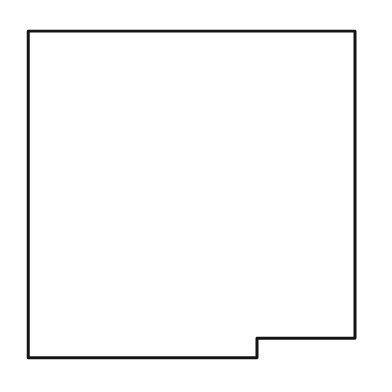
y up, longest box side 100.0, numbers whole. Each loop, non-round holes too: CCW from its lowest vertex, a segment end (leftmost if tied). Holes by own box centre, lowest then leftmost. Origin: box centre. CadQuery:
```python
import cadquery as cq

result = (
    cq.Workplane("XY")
    .moveTo(-50.0, -50.0)
    .lineTo(20.0, -50.0)
    .lineTo(20.0, -44.0)
    .lineTo(50.0, -44.0)
    .lineTo(50.0, 50.0)
    .lineTo(-50.0, 50.0)
    .close()
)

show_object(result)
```